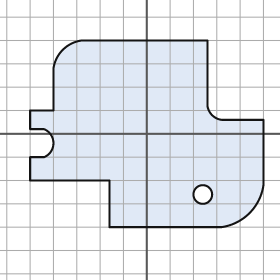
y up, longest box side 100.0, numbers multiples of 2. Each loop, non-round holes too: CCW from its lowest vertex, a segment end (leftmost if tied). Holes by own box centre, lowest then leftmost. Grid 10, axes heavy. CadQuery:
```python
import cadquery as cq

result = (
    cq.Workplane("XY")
    .moveTo(-16.0, -40.0)
    .lineTo(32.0, -40.0)
    .threePointArc((44.0, -34.0), (50.0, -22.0))
    .lineTo(50.0, 6.0)
    .lineTo(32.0, 6.0)
    .threePointArc((28.0, 8.0), (26.0, 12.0))
    .lineTo(26.0, 40.0)
    .lineTo(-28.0, 40.0)
    .threePointArc((-36.0, 36.0), (-40.0, 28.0))
    .lineTo(-40.0, 10.0)
    .lineTo(-50.0, 10.0)
    .lineTo(-50.0, 2.0)
    .lineTo(-44.0, 2.0)
    .threePointArc((-40.0, -4.0), (-44.0, -10.0))
    .lineTo(-50.0, -10.0)
    .lineTo(-50.0, -20.0)
    .lineTo(-16.0, -20.0)
    .close()
    .moveTo(24.0, -26.0)
    .circle(4.0)
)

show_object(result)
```